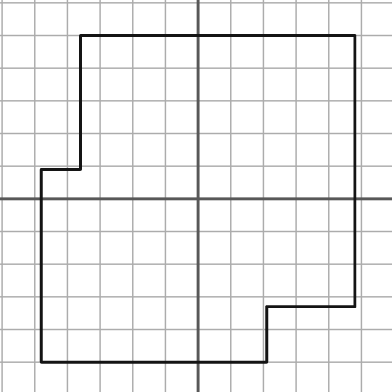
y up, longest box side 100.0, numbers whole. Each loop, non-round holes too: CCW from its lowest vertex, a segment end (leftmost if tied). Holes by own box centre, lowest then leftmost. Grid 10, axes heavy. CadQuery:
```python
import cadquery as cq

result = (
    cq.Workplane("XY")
    .moveTo(-48.0, -50.0)
    .lineTo(21.0, -50.0)
    .lineTo(21.0, -33.0)
    .lineTo(48.0, -33.0)
    .lineTo(48.0, 50.0)
    .lineTo(-36.0, 50.0)
    .lineTo(-36.0, 9.0)
    .lineTo(-48.0, 9.0)
    .close()
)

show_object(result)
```